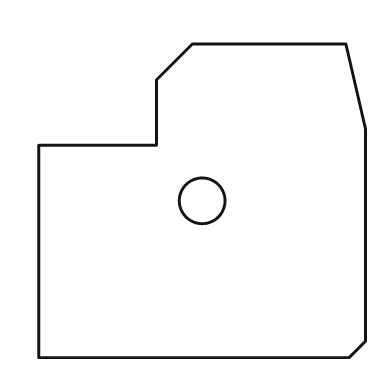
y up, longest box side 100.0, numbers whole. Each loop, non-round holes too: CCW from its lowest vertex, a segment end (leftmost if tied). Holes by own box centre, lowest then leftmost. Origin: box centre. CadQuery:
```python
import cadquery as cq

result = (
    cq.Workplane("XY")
    .moveTo(-50.0, -48.0)
    .lineTo(45.0, -48.0)
    .lineTo(50.0, -43.0)
    .lineTo(50.0, 22.0)
    .lineTo(44.0, 48.0)
    .lineTo(-3.0, 48.0)
    .lineTo(-14.0, 37.0)
    .lineTo(-14.0, 17.0)
    .lineTo(-50.0, 17.0)
    .close()
    .moveTo(0.0, 0.0)
    .circle(7.0)
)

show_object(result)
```